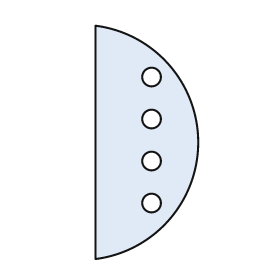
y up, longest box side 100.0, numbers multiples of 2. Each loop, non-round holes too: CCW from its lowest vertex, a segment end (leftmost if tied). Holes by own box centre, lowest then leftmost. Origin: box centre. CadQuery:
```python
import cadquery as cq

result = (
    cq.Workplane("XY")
    .moveTo(-22.0, -50.0)
    .threePointArc((22.0, 0.0), (-22.0, 50.0))
    .close()
    .moveTo(2.0, -26.0)
    .circle(4.0)
    .moveTo(2.0, -8.0)
    .circle(4.0)
    .moveTo(2.0, 10.0)
    .circle(4.0)
    .moveTo(2.0, 28.0)
    .circle(4.0)
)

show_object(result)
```